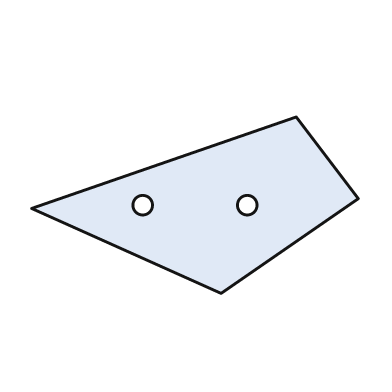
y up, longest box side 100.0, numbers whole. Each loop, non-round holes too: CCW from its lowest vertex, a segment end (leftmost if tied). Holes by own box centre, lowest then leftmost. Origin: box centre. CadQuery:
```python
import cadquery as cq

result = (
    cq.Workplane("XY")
    .moveTo(8.0, -27.0)
    .lineTo(50.0, 2.0)
    .lineTo(31.0, 27.0)
    .lineTo(-50.0, -1.0)
    .close()
    .moveTo(-16.0, 0.0)
    .circle(3.0)
    .moveTo(16.0, 0.0)
    .circle(3.0)
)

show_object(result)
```